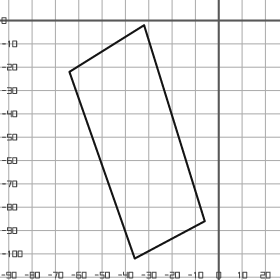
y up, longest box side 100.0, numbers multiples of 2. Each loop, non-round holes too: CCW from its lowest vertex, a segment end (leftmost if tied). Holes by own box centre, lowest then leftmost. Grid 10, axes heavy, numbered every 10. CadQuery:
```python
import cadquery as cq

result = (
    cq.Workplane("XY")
    .moveTo(-36.0, -102.0)
    .lineTo(-6.0, -86.0)
    .lineTo(-32.0, -2.0)
    .lineTo(-64.0, -22.0)
    .close()
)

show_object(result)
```